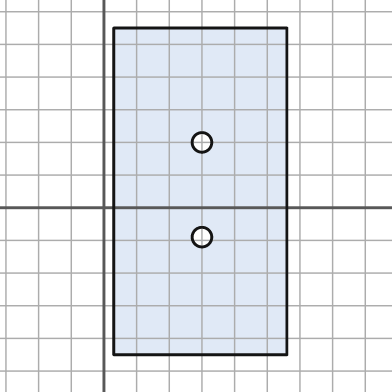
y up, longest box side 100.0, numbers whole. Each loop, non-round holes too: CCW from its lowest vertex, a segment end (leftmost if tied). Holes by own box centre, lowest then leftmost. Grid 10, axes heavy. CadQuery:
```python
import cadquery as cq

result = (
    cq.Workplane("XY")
    .moveTo(3.0, -45.0)
    .lineTo(56.0, -45.0)
    .lineTo(56.0, 55.0)
    .lineTo(3.0, 55.0)
    .close()
    .moveTo(30.0, -9.0)
    .circle(3.0)
    .moveTo(30.0, 20.0)
    .circle(3.0)
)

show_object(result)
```